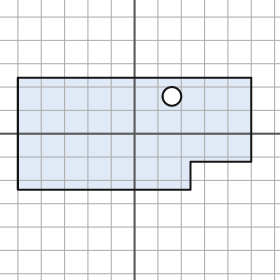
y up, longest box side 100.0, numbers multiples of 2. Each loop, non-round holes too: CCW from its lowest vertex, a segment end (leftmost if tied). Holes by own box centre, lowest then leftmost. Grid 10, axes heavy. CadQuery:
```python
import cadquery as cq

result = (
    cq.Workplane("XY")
    .moveTo(-50.0, -24.0)
    .lineTo(24.0, -24.0)
    .lineTo(24.0, -12.0)
    .lineTo(50.0, -12.0)
    .lineTo(50.0, 24.0)
    .lineTo(-50.0, 24.0)
    .close()
    .moveTo(16.0, 16.0)
    .circle(4.0)
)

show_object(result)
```